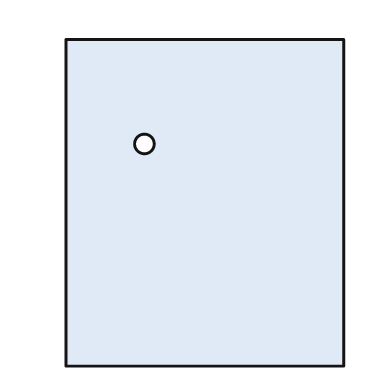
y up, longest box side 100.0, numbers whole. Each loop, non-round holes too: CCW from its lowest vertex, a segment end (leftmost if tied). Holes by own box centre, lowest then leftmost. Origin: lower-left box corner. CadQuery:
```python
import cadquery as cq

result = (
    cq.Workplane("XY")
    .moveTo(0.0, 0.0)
    .lineTo(85.0, 0.0)
    .lineTo(85.0, 100.0)
    .lineTo(0.0, 100.0)
    .close()
    .moveTo(24.0, 68.0)
    .circle(3.0)
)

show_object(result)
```